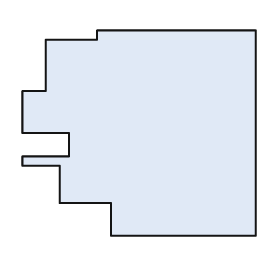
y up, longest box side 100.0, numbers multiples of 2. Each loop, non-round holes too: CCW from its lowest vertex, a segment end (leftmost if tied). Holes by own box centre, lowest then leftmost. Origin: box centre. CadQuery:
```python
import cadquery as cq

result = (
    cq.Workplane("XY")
    .moveTo(-12.0, -44.0)
    .lineTo(50.0, -44.0)
    .lineTo(50.0, 44.0)
    .lineTo(-18.0, 44.0)
    .lineTo(-18.0, 40.0)
    .lineTo(-40.0, 40.0)
    .lineTo(-40.0, 18.0)
    .lineTo(-50.0, 18.0)
    .lineTo(-50.0, 0.0)
    .lineTo(-30.0, 0.0)
    .lineTo(-30.0, -10.0)
    .lineTo(-50.0, -10.0)
    .lineTo(-50.0, -14.0)
    .lineTo(-34.0, -14.0)
    .lineTo(-34.0, -30.0)
    .lineTo(-12.0, -30.0)
    .close()
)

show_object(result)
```